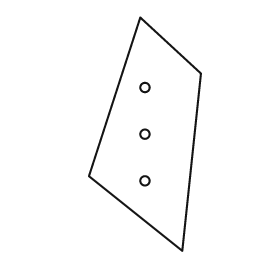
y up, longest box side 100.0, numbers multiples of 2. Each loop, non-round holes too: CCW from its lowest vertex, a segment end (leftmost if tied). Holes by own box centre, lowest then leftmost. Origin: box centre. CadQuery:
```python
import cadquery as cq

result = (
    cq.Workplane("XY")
    .moveTo(16.0, -50.0)
    .lineTo(24.0, 26.0)
    .lineTo(-2.0, 50.0)
    .lineTo(-24.0, -18.0)
    .close()
    .moveTo(0.0, -20.0)
    .circle(2.0)
    .moveTo(0.0, 0.0)
    .circle(2.0)
    .moveTo(0.0, 20.0)
    .circle(2.0)
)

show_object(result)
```